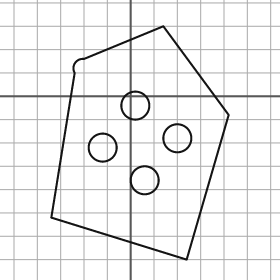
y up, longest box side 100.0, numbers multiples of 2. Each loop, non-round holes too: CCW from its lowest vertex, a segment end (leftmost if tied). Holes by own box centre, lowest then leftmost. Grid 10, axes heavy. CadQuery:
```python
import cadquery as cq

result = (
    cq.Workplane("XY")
    .moveTo(24.0, -70.0)
    .lineTo(42.0, -8.0)
    .lineTo(14.0, 30.0)
    .lineTo(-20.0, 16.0)
    .threePointArc((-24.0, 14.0), (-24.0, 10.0))
    .lineTo(-34.0, -52.0)
    .close()
    .moveTo(6.0, -36.0)
    .circle(6.0)
    .moveTo(-12.0, -22.0)
    .circle(6.0)
    .moveTo(20.0, -18.0)
    .circle(6.0)
    .moveTo(2.0, -4.0)
    .circle(6.0)
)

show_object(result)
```